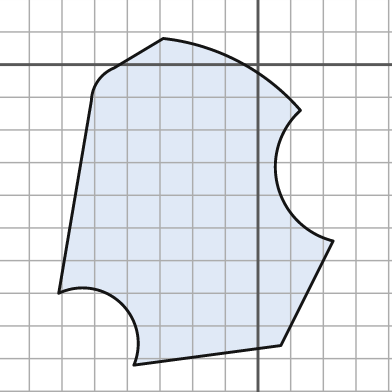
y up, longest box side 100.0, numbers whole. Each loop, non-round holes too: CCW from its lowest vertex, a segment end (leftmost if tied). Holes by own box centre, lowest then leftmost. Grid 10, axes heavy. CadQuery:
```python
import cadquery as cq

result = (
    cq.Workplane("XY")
    .moveTo(-38.0, -92.0)
    .lineTo(7.0, -86.0)
    .lineTo(23.0, -54.0)
    .threePointArc((6.0, -37.0), (13.0, -14.0))
    .threePointArc((-6.0, 1.0), (-29.0, 8.0))
    .lineTo(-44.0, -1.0)
    .threePointArc((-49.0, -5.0), (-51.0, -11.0))
    .lineTo(-61.0, -70.0)
    .threePointArc((-42.0, -73.0), (-38.0, -92.0))
    .close()
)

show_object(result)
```